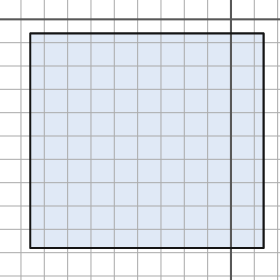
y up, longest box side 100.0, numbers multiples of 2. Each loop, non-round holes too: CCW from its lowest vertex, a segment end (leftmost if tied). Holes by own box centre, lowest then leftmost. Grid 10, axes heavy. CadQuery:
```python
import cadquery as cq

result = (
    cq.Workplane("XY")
    .moveTo(-86.0, -98.0)
    .lineTo(14.0, -98.0)
    .lineTo(14.0, -6.0)
    .lineTo(-86.0, -6.0)
    .close()
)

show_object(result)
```